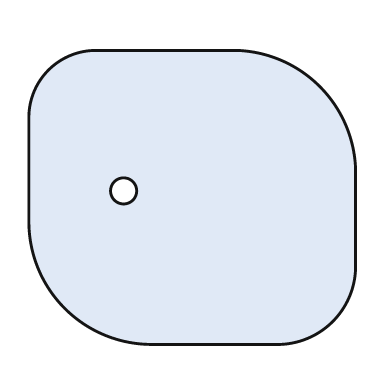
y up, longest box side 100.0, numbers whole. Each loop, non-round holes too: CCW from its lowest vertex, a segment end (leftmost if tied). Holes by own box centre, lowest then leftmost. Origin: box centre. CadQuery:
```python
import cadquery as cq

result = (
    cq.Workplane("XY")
    .moveTo(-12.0, -45.0)
    .lineTo(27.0, -45.0)
    .threePointArc((43.0, -38.0), (50.0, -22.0))
    .lineTo(50.0, 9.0)
    .threePointArc((39.0, 34.0), (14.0, 45.0))
    .lineTo(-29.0, 45.0)
    .threePointArc((-44.0, 39.0), (-50.0, 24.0))
    .lineTo(-50.0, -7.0)
    .threePointArc((-39.0, -34.0), (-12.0, -45.0))
    .close()
    .moveTo(-21.0, 2.0)
    .circle(4.0)
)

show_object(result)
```